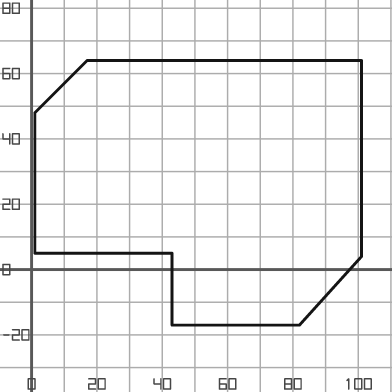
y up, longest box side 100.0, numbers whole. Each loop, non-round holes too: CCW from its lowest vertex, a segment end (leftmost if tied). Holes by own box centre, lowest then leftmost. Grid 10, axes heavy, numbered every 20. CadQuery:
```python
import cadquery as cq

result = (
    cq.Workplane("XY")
    .moveTo(43.0, -17.0)
    .lineTo(82.0, -17.0)
    .lineTo(101.0, 4.0)
    .lineTo(101.0, 64.0)
    .lineTo(17.0, 64.0)
    .lineTo(1.0, 48.0)
    .lineTo(1.0, 5.0)
    .lineTo(43.0, 5.0)
    .close()
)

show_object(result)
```